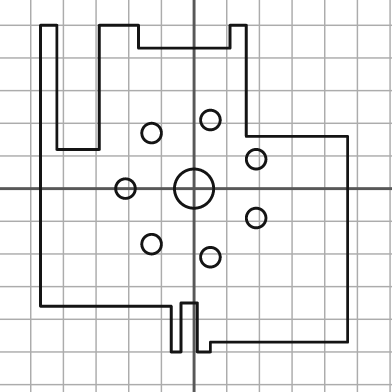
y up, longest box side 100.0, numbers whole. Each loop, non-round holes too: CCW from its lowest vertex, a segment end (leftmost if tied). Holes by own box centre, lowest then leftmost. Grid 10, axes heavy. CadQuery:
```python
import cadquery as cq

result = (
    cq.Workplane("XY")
    .moveTo(-7.0, -50.0)
    .lineTo(-4.0, -50.0)
    .lineTo(-4.0, -35.0)
    .lineTo(1.0, -35.0)
    .lineTo(1.0, -50.0)
    .lineTo(5.0, -50.0)
    .lineTo(5.0, -47.0)
    .lineTo(47.0, -47.0)
    .lineTo(47.0, 16.0)
    .lineTo(16.0, 16.0)
    .lineTo(16.0, 50.0)
    .lineTo(11.0, 50.0)
    .lineTo(11.0, 43.0)
    .lineTo(-17.0, 43.0)
    .lineTo(-17.0, 50.0)
    .lineTo(-29.0, 50.0)
    .lineTo(-29.0, 12.0)
    .lineTo(-42.0, 12.0)
    .lineTo(-42.0, 50.0)
    .lineTo(-47.0, 50.0)
    .lineTo(-47.0, -36.0)
    .lineTo(-7.0, -36.0)
    .close()
    .moveTo(5.0, -21.0)
    .circle(3.0)
    .moveTo(-13.0, -17.0)
    .circle(3.0)
    .moveTo(19.0, -9.0)
    .circle(3.0)
    .moveTo(-21.0, 0.0)
    .circle(3.0)
    .moveTo(0.0, 0.0)
    .circle(6.0)
    .moveTo(19.0, 9.0)
    .circle(3.0)
    .moveTo(-13.0, 17.0)
    .circle(3.0)
    .moveTo(5.0, 21.0)
    .circle(3.0)
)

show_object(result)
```